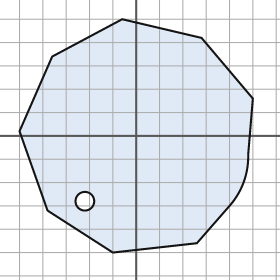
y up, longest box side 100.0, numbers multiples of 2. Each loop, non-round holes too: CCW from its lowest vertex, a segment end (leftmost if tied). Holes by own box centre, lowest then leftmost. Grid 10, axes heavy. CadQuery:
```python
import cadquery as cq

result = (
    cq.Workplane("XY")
    .moveTo(-10.0, -50.0)
    .lineTo(26.0, -46.0)
    .lineTo(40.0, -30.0)
    .threePointArc((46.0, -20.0), (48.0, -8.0))
    .lineTo(50.0, 16.0)
    .lineTo(28.0, 42.0)
    .lineTo(-6.0, 50.0)
    .lineTo(-36.0, 34.0)
    .lineTo(-50.0, 2.0)
    .lineTo(-38.0, -32.0)
    .close()
    .moveTo(-22.0, -28.0)
    .circle(4.0)
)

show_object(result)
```